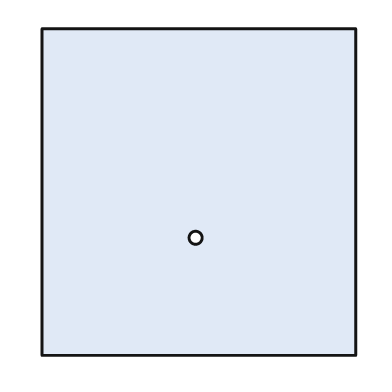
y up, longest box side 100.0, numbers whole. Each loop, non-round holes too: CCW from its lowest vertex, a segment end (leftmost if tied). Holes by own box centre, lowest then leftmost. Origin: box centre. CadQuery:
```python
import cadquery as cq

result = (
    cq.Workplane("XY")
    .moveTo(-48.0, -50.0)
    .lineTo(48.0, -50.0)
    .lineTo(48.0, 50.0)
    .lineTo(-48.0, 50.0)
    .close()
    .moveTo(-1.0, -14.0)
    .circle(2.0)
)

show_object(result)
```